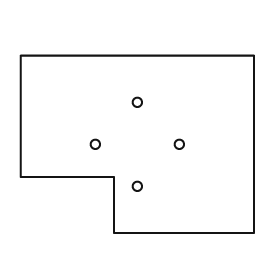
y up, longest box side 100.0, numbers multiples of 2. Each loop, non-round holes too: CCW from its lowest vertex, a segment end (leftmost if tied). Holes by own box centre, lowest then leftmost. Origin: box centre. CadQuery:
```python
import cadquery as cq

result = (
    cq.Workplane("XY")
    .moveTo(-10.0, -38.0)
    .lineTo(50.0, -38.0)
    .lineTo(50.0, 38.0)
    .lineTo(-50.0, 38.0)
    .lineTo(-50.0, -14.0)
    .lineTo(-10.0, -14.0)
    .close()
    .moveTo(0.0, -18.0)
    .circle(2.0)
    .moveTo(-18.0, 0.0)
    .circle(2.0)
    .moveTo(18.0, 0.0)
    .circle(2.0)
    .moveTo(0.0, 18.0)
    .circle(2.0)
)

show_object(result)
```